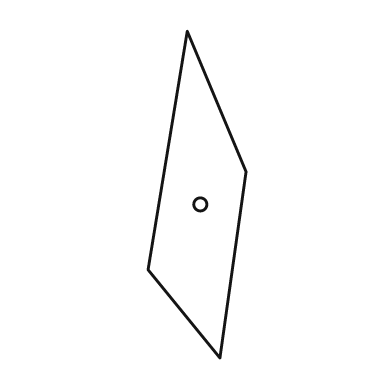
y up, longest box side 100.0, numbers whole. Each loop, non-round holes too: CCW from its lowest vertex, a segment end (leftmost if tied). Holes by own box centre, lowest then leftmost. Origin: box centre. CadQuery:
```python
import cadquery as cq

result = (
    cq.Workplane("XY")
    .moveTo(7.0, -50.0)
    .lineTo(15.0, 7.0)
    .lineTo(-3.0, 50.0)
    .lineTo(-15.0, -23.0)
    .close()
    .moveTo(1.0, -3.0)
    .circle(2.0)
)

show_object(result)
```